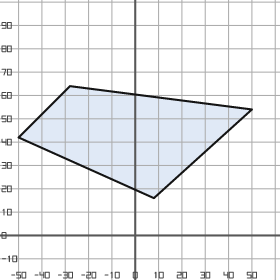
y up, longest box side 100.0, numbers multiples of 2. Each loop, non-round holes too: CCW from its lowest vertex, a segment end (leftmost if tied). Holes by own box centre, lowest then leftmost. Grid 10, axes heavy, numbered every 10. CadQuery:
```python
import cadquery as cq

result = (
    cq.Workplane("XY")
    .moveTo(8.0, 16.0)
    .lineTo(50.0, 54.0)
    .lineTo(-28.0, 64.0)
    .lineTo(-50.0, 42.0)
    .close()
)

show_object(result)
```